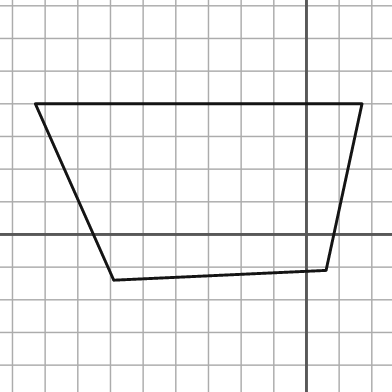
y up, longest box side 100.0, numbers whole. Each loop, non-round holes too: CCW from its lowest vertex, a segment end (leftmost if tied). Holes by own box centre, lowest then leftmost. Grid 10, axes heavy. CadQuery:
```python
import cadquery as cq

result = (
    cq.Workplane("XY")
    .moveTo(-59.0, -14.0)
    .lineTo(6.0, -11.0)
    .lineTo(17.0, 40.0)
    .lineTo(-83.0, 40.0)
    .close()
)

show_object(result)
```